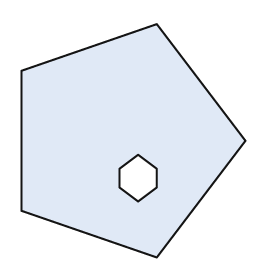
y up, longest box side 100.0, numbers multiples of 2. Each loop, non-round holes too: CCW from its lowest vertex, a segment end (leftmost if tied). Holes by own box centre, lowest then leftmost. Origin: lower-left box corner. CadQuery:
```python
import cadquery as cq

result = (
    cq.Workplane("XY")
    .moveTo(58.0, 0.0)
    .lineTo(96.0, 50.0)
    .lineTo(58.0, 100.0)
    .lineTo(0.0, 80.0)
    .lineTo(0.0, 20.0)
    .close()
    .moveTo(50.0, 24.0)
    .lineTo(58.0, 30.0)
    .lineTo(58.0, 38.0)
    .lineTo(50.0, 44.0)
    .lineTo(42.0, 38.0)
    .lineTo(42.0, 30.0)
    .close()
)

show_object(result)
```